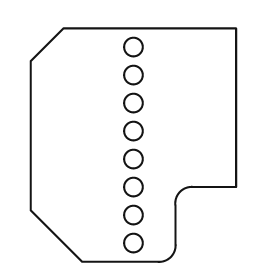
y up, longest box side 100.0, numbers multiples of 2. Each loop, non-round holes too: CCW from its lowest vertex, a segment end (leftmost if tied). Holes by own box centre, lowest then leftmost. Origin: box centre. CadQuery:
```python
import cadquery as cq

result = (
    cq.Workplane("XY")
    .moveTo(-22.0, -50.0)
    .lineTo(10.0, -50.0)
    .threePointArc((16.0, -48.0), (18.0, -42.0))
    .lineTo(18.0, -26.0)
    .threePointArc((20.0, -20.0), (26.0, -18.0))
    .lineTo(44.0, -18.0)
    .lineTo(44.0, 50.0)
    .lineTo(-30.0, 50.0)
    .lineTo(-44.0, 36.0)
    .lineTo(-44.0, -28.0)
    .close()
    .moveTo(0.0, -42.0)
    .circle(4.0)
    .moveTo(0.0, -30.0)
    .circle(4.0)
    .moveTo(0.0, -18.0)
    .circle(4.0)
    .moveTo(0.0, -6.0)
    .circle(4.0)
    .moveTo(0.0, 6.0)
    .circle(4.0)
    .moveTo(0.0, 18.0)
    .circle(4.0)
    .moveTo(0.0, 30.0)
    .circle(4.0)
    .moveTo(0.0, 42.0)
    .circle(4.0)
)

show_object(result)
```